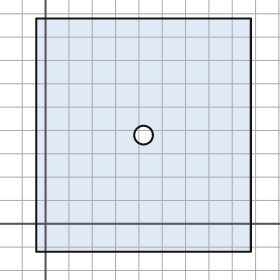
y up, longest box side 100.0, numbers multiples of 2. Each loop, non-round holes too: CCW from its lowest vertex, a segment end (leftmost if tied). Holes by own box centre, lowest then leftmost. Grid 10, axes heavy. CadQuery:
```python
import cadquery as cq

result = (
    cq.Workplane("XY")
    .moveTo(-4.0, -12.0)
    .lineTo(88.0, -12.0)
    .lineTo(88.0, 88.0)
    .lineTo(-4.0, 88.0)
    .close()
    .moveTo(42.0, 38.0)
    .circle(4.0)
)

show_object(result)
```